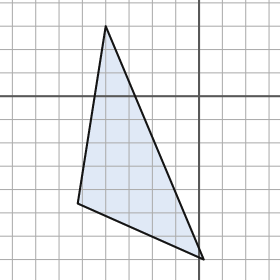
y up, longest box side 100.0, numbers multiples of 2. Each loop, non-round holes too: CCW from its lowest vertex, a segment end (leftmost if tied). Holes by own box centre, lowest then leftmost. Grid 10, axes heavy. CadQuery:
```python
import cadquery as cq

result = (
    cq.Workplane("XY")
    .moveTo(2.0, -70.0)
    .lineTo(-40.0, 30.0)
    .lineTo(-52.0, -46.0)
    .close()
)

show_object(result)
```